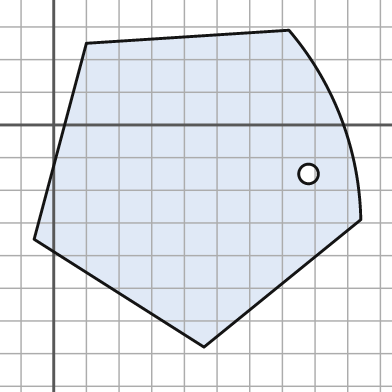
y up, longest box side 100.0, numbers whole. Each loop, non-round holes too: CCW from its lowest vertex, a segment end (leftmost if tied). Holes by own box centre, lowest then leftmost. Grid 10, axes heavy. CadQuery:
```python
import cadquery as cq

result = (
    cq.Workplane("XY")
    .moveTo(46.0, -68.0)
    .lineTo(94.0, -29.0)
    .threePointArc((88.0, 2.0), (72.0, 29.0))
    .lineTo(10.0, 25.0)
    .lineTo(-6.0, -35.0)
    .close()
    .moveTo(78.0, -15.0)
    .circle(3.0)
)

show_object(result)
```